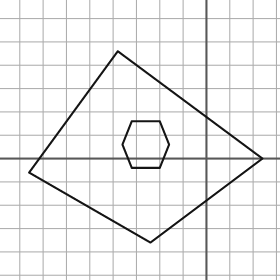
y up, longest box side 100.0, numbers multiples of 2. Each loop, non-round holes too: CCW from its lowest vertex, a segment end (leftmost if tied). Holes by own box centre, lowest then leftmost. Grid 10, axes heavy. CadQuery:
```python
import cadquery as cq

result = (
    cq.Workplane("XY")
    .moveTo(-24.0, -36.0)
    .lineTo(24.0, 0.0)
    .lineTo(-38.0, 46.0)
    .lineTo(-76.0, -6.0)
    .close()
    .moveTo(-32.0, -4.0)
    .lineTo(-20.0, -4.0)
    .lineTo(-16.0, 6.0)
    .lineTo(-20.0, 16.0)
    .lineTo(-32.0, 16.0)
    .lineTo(-36.0, 6.0)
    .close()
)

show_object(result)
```